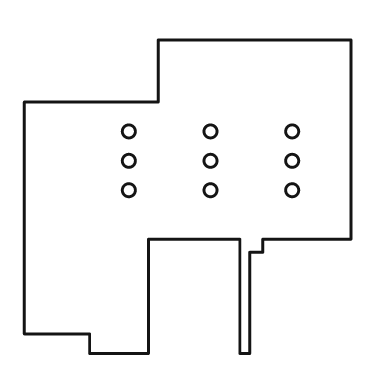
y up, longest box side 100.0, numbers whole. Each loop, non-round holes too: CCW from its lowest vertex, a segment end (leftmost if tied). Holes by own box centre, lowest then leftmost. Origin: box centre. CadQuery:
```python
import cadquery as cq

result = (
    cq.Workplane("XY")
    .moveTo(-30.0, -48.0)
    .lineTo(-12.0, -48.0)
    .lineTo(-12.0, -13.0)
    .lineTo(16.0, -13.0)
    .lineTo(16.0, -48.0)
    .lineTo(19.0, -48.0)
    .lineTo(19.0, -17.0)
    .lineTo(23.0, -17.0)
    .lineTo(23.0, -13.0)
    .lineTo(50.0, -13.0)
    .lineTo(50.0, 48.0)
    .lineTo(-9.0, 48.0)
    .lineTo(-9.0, 29.0)
    .lineTo(-50.0, 29.0)
    .lineTo(-50.0, -42.0)
    .lineTo(-30.0, -42.0)
    .close()
    .moveTo(-18.0, 2.0)
    .circle(2.0)
    .moveTo(7.0, 2.0)
    .circle(2.0)
    .moveTo(32.0, 2.0)
    .circle(2.0)
    .moveTo(-18.0, 11.0)
    .circle(2.0)
    .moveTo(7.0, 11.0)
    .circle(2.0)
    .moveTo(32.0, 11.0)
    .circle(2.0)
    .moveTo(-18.0, 20.0)
    .circle(2.0)
    .moveTo(7.0, 20.0)
    .circle(2.0)
    .moveTo(32.0, 20.0)
    .circle(2.0)
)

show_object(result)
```